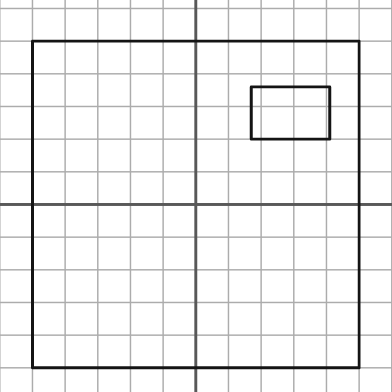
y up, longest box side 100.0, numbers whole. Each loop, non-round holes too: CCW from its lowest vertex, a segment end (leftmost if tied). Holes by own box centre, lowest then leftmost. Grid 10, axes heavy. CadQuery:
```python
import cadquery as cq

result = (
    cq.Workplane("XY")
    .moveTo(-50.0, -50.0)
    .lineTo(50.0, -50.0)
    .lineTo(50.0, 50.0)
    .lineTo(-50.0, 50.0)
    .close()
    .moveTo(17.0, 20.0)
    .lineTo(41.0, 20.0)
    .lineTo(41.0, 36.0)
    .lineTo(17.0, 36.0)
    .close()
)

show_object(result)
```